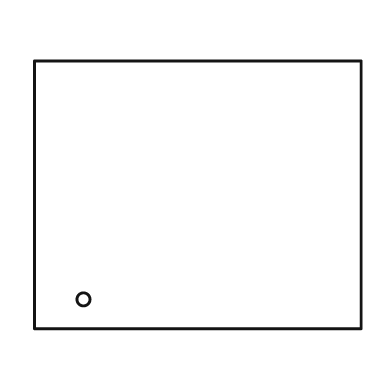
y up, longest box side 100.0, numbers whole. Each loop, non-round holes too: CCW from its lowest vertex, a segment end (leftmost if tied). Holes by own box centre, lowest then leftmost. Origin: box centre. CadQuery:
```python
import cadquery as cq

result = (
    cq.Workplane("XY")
    .moveTo(-50.0, -41.0)
    .lineTo(50.0, -41.0)
    .lineTo(50.0, 41.0)
    .lineTo(-50.0, 41.0)
    .close()
    .moveTo(-35.0, -32.0)
    .circle(2.0)
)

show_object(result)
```